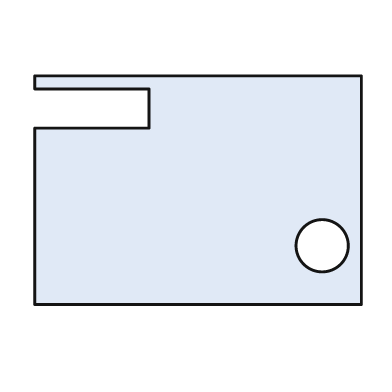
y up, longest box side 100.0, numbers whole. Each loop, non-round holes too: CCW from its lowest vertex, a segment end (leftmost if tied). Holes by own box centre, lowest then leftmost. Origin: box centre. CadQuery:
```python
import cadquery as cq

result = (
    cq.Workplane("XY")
    .moveTo(-50.0, -35.0)
    .lineTo(50.0, -35.0)
    .lineTo(50.0, 35.0)
    .lineTo(-50.0, 35.0)
    .lineTo(-50.0, 31.0)
    .lineTo(-15.0, 31.0)
    .lineTo(-15.0, 19.0)
    .lineTo(-50.0, 19.0)
    .close()
    .moveTo(38.0, -17.0)
    .circle(8.0)
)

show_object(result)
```